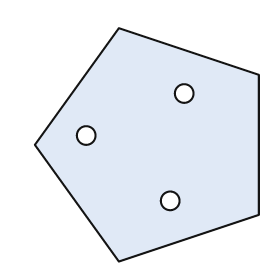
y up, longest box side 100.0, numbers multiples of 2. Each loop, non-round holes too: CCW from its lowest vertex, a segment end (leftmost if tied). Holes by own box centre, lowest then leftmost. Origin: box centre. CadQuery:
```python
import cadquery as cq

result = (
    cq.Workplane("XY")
    .moveTo(-12.0, -50.0)
    .lineTo(48.0, -30.0)
    .lineTo(48.0, 30.0)
    .lineTo(-12.0, 50.0)
    .lineTo(-48.0, 0.0)
    .close()
    .moveTo(10.0, -24.0)
    .circle(4.0)
    .moveTo(-26.0, 4.0)
    .circle(4.0)
    .moveTo(16.0, 22.0)
    .circle(4.0)
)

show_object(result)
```